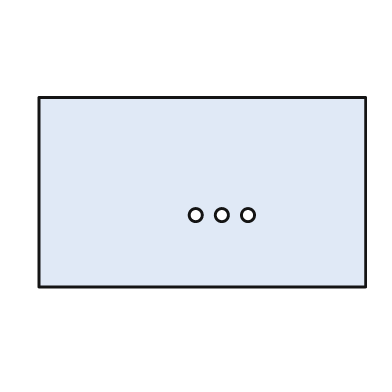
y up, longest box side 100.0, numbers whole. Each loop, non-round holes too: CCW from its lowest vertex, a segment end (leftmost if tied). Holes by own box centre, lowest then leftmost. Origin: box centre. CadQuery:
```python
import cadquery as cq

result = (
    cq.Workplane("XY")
    .moveTo(-50.0, -29.0)
    .lineTo(50.0, -29.0)
    .lineTo(50.0, 29.0)
    .lineTo(-50.0, 29.0)
    .close()
    .moveTo(-2.0, -7.0)
    .circle(2.0)
    .moveTo(6.0, -7.0)
    .circle(2.0)
    .moveTo(14.0, -7.0)
    .circle(2.0)
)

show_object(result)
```